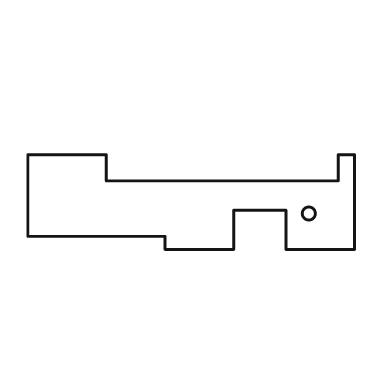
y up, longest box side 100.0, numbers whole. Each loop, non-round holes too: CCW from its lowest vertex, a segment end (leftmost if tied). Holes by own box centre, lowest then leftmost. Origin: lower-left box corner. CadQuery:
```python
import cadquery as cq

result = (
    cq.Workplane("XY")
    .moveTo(42.0, 0.0)
    .lineTo(63.0, 0.0)
    .lineTo(63.0, 12.0)
    .lineTo(79.0, 12.0)
    .lineTo(79.0, 0.0)
    .lineTo(100.0, 0.0)
    .lineTo(100.0, 29.0)
    .lineTo(95.0, 29.0)
    .lineTo(95.0, 21.0)
    .lineTo(24.0, 21.0)
    .lineTo(24.0, 29.0)
    .lineTo(0.0, 29.0)
    .lineTo(0.0, 4.0)
    .lineTo(42.0, 4.0)
    .close()
    .moveTo(86.0, 11.0)
    .circle(2.0)
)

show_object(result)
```